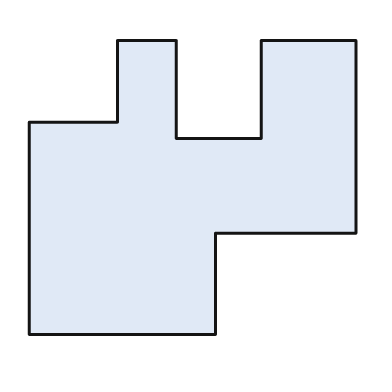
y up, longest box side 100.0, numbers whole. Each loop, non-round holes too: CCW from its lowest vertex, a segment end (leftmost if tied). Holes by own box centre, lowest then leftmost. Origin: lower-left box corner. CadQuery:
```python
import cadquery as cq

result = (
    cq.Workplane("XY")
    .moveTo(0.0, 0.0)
    .lineTo(57.0, 0.0)
    .lineTo(57.0, 31.0)
    .lineTo(100.0, 31.0)
    .lineTo(100.0, 90.0)
    .lineTo(71.0, 90.0)
    .lineTo(71.0, 60.0)
    .lineTo(45.0, 60.0)
    .lineTo(45.0, 90.0)
    .lineTo(27.0, 90.0)
    .lineTo(27.0, 65.0)
    .lineTo(0.0, 65.0)
    .close()
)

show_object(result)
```